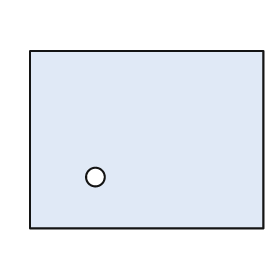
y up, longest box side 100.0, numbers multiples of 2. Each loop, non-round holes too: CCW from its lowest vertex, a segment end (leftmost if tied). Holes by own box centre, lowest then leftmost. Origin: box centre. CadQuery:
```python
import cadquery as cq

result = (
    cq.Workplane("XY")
    .moveTo(-50.0, -38.0)
    .lineTo(50.0, -38.0)
    .lineTo(50.0, 38.0)
    .lineTo(-50.0, 38.0)
    .close()
    .moveTo(-22.0, -16.0)
    .circle(4.0)
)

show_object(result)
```